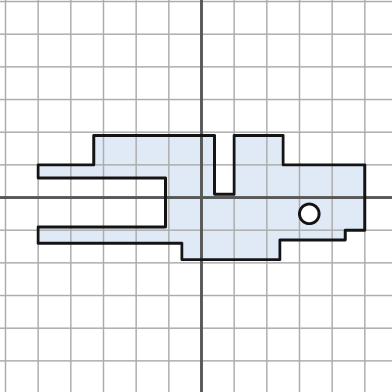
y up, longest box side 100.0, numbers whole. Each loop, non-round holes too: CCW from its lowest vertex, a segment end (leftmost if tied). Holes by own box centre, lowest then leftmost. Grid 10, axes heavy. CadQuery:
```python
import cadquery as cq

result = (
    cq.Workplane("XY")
    .moveTo(-6.0, -19.0)
    .lineTo(24.0, -19.0)
    .lineTo(24.0, -13.0)
    .lineTo(44.0, -13.0)
    .lineTo(44.0, -10.0)
    .lineTo(50.0, -10.0)
    .lineTo(50.0, 10.0)
    .lineTo(25.0, 10.0)
    .lineTo(25.0, 19.0)
    .lineTo(10.0, 19.0)
    .lineTo(10.0, 1.0)
    .lineTo(4.0, 1.0)
    .lineTo(4.0, 19.0)
    .lineTo(-33.0, 19.0)
    .lineTo(-33.0, 10.0)
    .lineTo(-50.0, 10.0)
    .lineTo(-50.0, 6.0)
    .lineTo(-11.0, 6.0)
    .lineTo(-11.0, -9.0)
    .lineTo(-50.0, -9.0)
    .lineTo(-50.0, -14.0)
    .lineTo(-6.0, -14.0)
    .close()
    .moveTo(33.0, -5.0)
    .circle(3.0)
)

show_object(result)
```